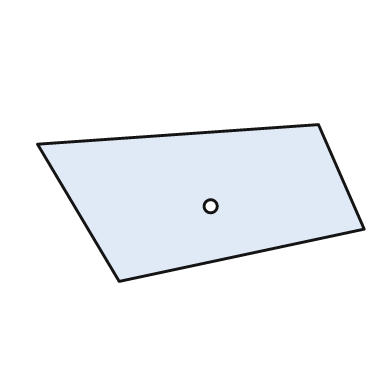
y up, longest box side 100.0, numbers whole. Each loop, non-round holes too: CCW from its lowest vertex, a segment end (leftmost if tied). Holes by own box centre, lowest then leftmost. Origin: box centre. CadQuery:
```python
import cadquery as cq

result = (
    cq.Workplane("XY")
    .moveTo(-25.0, -24.0)
    .lineTo(50.0, -8.0)
    .lineTo(36.0, 24.0)
    .lineTo(-50.0, 18.0)
    .close()
    .moveTo(3.0, -1.0)
    .circle(2.0)
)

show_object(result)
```